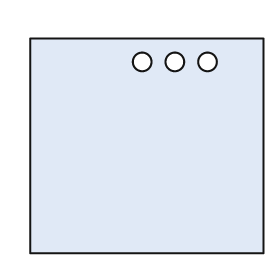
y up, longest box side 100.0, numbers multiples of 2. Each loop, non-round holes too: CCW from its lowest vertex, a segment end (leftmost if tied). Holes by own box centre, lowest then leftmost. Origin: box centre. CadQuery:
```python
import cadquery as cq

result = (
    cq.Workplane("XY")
    .moveTo(-50.0, -46.0)
    .lineTo(50.0, -46.0)
    .lineTo(50.0, 46.0)
    .lineTo(-50.0, 46.0)
    .close()
    .moveTo(-2.0, 36.0)
    .circle(4.0)
    .moveTo(12.0, 36.0)
    .circle(4.0)
    .moveTo(26.0, 36.0)
    .circle(4.0)
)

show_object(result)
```